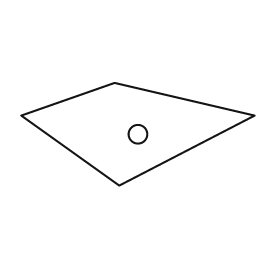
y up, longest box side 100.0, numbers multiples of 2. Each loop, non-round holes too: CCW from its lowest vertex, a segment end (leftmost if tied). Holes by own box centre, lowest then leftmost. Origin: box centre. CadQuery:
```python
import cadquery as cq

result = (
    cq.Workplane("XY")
    .moveTo(-8.0, -22.0)
    .lineTo(50.0, 8.0)
    .lineTo(-10.0, 22.0)
    .lineTo(-50.0, 8.0)
    .close()
    .moveTo(0.0, 0.0)
    .circle(4.0)
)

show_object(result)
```